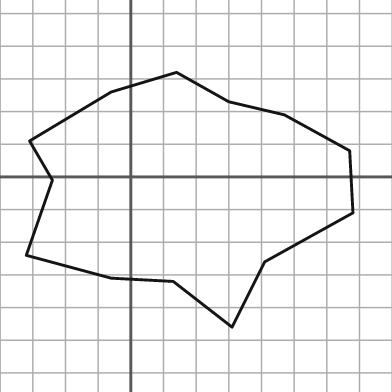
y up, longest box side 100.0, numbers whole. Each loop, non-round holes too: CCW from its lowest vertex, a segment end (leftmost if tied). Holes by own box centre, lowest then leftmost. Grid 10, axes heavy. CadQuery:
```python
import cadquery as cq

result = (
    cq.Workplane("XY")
    .moveTo(31.0, -46.0)
    .lineTo(41.0, -26.0)
    .lineTo(68.0, -11.0)
    .lineTo(67.0, 8.0)
    .lineTo(47.0, 19.0)
    .lineTo(30.0, 23.0)
    .lineTo(14.0, 32.0)
    .lineTo(-6.0, 26.0)
    .lineTo(-31.0, 11.0)
    .lineTo(-24.0, -1.0)
    .lineTo(-32.0, -24.0)
    .lineTo(-6.0, -31.0)
    .lineTo(13.0, -32.0)
    .close()
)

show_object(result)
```